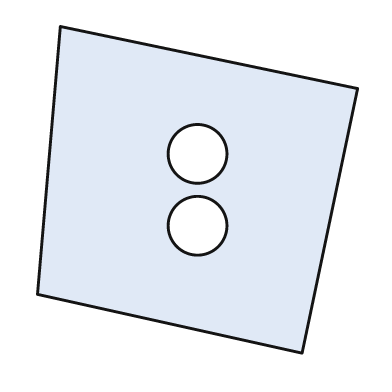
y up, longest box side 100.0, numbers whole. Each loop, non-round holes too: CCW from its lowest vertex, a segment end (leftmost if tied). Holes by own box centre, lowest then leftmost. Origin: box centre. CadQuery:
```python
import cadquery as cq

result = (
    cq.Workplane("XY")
    .moveTo(32.0, -50.0)
    .lineTo(49.0, 31.0)
    .lineTo(-42.0, 50.0)
    .lineTo(-49.0, -32.0)
    .close()
    .moveTo(0.0, -11.0)
    .circle(9.0)
    .moveTo(0.0, 11.0)
    .circle(9.0)
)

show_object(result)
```